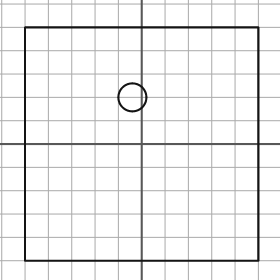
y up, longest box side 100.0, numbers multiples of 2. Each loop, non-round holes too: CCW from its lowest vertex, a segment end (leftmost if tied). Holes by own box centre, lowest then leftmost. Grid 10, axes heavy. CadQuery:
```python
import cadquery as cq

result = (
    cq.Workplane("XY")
    .moveTo(-50.0, -50.0)
    .lineTo(50.0, -50.0)
    .lineTo(50.0, 50.0)
    .lineTo(-50.0, 50.0)
    .close()
    .moveTo(-4.0, 20.0)
    .circle(6.0)
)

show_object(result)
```